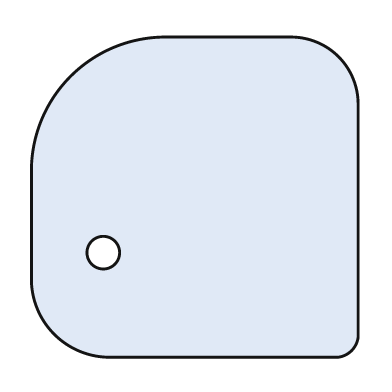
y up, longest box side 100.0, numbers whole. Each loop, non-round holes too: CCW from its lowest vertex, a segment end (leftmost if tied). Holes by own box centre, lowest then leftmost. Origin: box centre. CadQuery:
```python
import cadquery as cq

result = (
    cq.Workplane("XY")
    .moveTo(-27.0, -49.0)
    .lineTo(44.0, -49.0)
    .threePointArc((48.0, -47.0), (50.0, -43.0))
    .lineTo(50.0, 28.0)
    .threePointArc((44.0, 43.0), (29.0, 49.0))
    .lineTo(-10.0, 49.0)
    .threePointArc((-38.0, 37.0), (-50.0, 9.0))
    .lineTo(-50.0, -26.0)
    .threePointArc((-43.0, -42.0), (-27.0, -49.0))
    .close()
    .moveTo(-28.0, -17.0)
    .circle(5.0)
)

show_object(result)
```